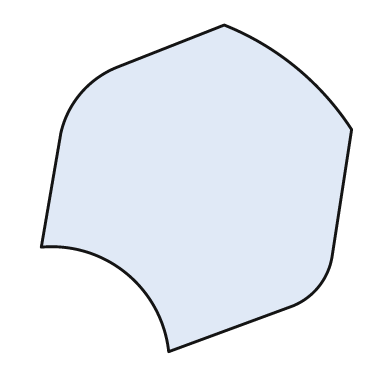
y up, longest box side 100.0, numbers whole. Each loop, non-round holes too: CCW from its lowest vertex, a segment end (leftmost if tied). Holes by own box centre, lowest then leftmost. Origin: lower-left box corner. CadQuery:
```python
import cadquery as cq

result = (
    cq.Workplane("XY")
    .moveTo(39.0, 0.0)
    .lineTo(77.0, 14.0)
    .threePointArc((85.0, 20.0), (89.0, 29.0))
    .lineTo(95.0, 68.0)
    .threePointArc((78.0, 87.0), (56.0, 100.0))
    .lineTo(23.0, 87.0)
    .threePointArc((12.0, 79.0), (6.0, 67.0))
    .lineTo(0.0, 32.0)
    .threePointArc((26.0, 24.0), (39.0, 0.0))
    .close()
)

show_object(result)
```